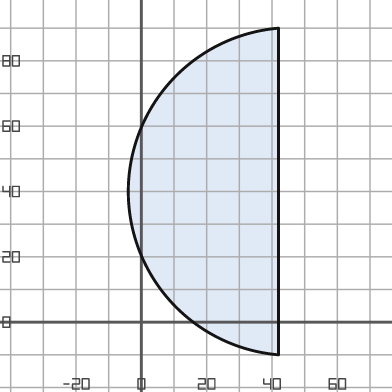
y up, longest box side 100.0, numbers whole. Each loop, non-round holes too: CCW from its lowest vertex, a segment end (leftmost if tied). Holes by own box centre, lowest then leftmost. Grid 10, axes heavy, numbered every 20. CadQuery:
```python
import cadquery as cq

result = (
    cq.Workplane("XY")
    .moveTo(42.0, -10.0)
    .lineTo(42.0, 90.0)
    .threePointArc((-4.0, 40.0), (42.0, -10.0))
    .close()
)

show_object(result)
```